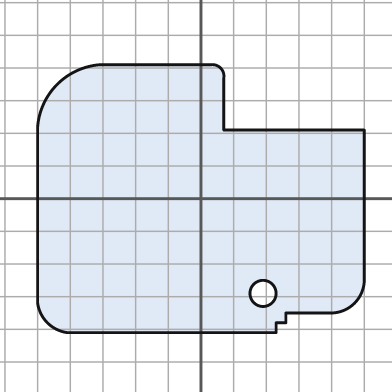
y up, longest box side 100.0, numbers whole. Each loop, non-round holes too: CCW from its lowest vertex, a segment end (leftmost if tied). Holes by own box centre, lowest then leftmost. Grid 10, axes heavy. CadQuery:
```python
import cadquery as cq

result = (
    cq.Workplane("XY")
    .moveTo(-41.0, -41.0)
    .lineTo(23.0, -41.0)
    .lineTo(23.0, -38.0)
    .lineTo(26.0, -38.0)
    .lineTo(26.0, -35.0)
    .lineTo(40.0, -35.0)
    .threePointArc((47.0, -32.0), (50.0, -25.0))
    .lineTo(50.0, 21.0)
    .lineTo(7.0, 21.0)
    .lineTo(7.0, 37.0)
    .threePointArc((6.0, 40.0), (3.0, 41.0))
    .lineTo(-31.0, 41.0)
    .threePointArc((-44.0, 35.0), (-50.0, 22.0))
    .lineTo(-50.0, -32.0)
    .threePointArc((-47.0, -38.0), (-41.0, -41.0))
    .close()
    .moveTo(19.0, -29.0)
    .circle(4.0)
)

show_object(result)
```